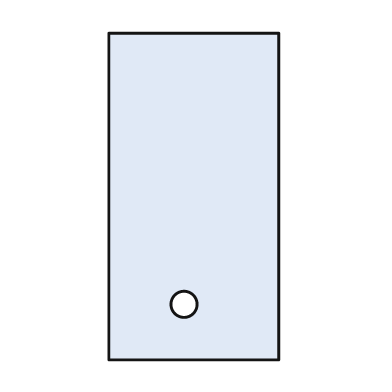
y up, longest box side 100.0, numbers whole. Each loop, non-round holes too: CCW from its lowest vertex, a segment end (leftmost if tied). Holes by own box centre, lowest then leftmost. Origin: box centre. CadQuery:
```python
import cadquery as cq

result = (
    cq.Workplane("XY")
    .moveTo(-26.0, -50.0)
    .lineTo(26.0, -50.0)
    .lineTo(26.0, 50.0)
    .lineTo(-26.0, 50.0)
    .close()
    .moveTo(-3.0, -33.0)
    .circle(4.0)
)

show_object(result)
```